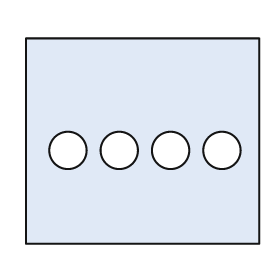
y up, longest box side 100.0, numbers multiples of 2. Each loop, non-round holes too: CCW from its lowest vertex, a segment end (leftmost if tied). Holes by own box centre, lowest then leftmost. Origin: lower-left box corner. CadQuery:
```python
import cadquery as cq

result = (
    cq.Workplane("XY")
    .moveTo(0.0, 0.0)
    .lineTo(100.0, 0.0)
    .lineTo(100.0, 88.0)
    .lineTo(0.0, 88.0)
    .close()
    .moveTo(18.0, 40.0)
    .circle(8.0)
    .moveTo(40.0, 40.0)
    .circle(8.0)
    .moveTo(62.0, 40.0)
    .circle(8.0)
    .moveTo(84.0, 40.0)
    .circle(8.0)
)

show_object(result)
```